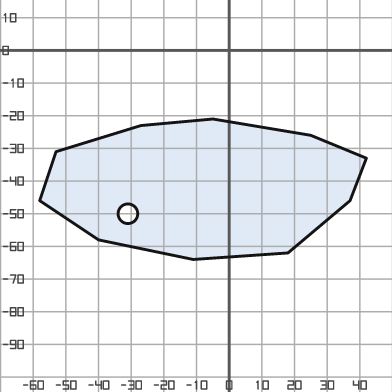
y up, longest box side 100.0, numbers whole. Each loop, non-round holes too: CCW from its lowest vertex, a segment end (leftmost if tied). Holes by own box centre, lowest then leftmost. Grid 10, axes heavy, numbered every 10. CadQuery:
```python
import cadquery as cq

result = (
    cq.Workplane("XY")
    .moveTo(-11.0, -64.0)
    .lineTo(18.0, -62.0)
    .lineTo(37.0, -46.0)
    .lineTo(42.0, -33.0)
    .lineTo(25.0, -26.0)
    .lineTo(-5.0, -21.0)
    .lineTo(-27.0, -23.0)
    .lineTo(-53.0, -31.0)
    .lineTo(-58.0, -46.0)
    .lineTo(-40.0, -58.0)
    .close()
    .moveTo(-31.0, -50.0)
    .circle(3.0)
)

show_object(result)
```